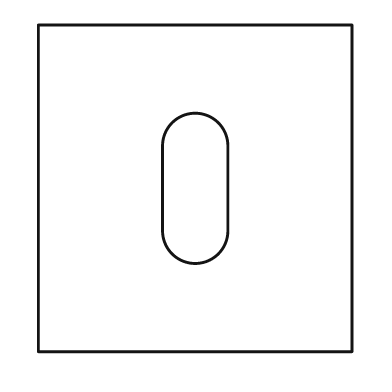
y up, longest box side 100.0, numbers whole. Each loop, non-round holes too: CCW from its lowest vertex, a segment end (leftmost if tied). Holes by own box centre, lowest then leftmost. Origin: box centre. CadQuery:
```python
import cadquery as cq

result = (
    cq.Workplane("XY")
    .moveTo(-48.0, -50.0)
    .lineTo(48.0, -50.0)
    .lineTo(48.0, 50.0)
    .lineTo(-48.0, 50.0)
    .close()
    .moveTo(-10.0, -13.0)
    .threePointArc((0.0, -23.0), (10.0, -13.0))
    .lineTo(10.0, 13.0)
    .threePointArc((0.0, 23.0), (-10.0, 13.0))
    .close()
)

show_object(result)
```